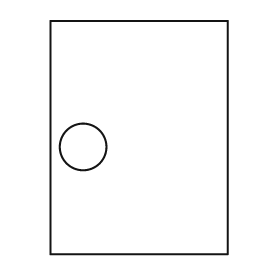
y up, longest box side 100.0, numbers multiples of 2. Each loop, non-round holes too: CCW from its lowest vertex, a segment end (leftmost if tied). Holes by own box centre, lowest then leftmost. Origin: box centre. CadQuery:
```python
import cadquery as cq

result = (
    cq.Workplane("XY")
    .moveTo(-38.0, -50.0)
    .lineTo(38.0, -50.0)
    .lineTo(38.0, 50.0)
    .lineTo(-38.0, 50.0)
    .close()
    .moveTo(-24.0, -4.0)
    .circle(10.0)
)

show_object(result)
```